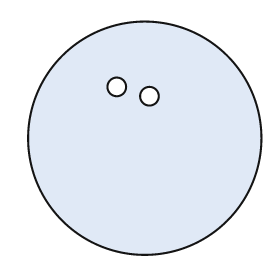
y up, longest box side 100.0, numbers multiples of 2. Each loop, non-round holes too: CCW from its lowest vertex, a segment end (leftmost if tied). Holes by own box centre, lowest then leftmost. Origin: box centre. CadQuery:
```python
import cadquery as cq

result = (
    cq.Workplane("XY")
    .moveTo(0.0, 0.0)
    .circle(50.0)
    .moveTo(2.0, 18.0)
    .circle(4.0)
    .moveTo(-12.0, 22.0)
    .circle(4.0)
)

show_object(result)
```